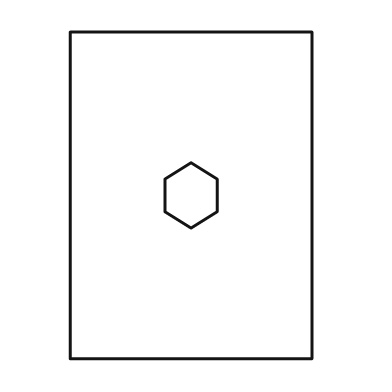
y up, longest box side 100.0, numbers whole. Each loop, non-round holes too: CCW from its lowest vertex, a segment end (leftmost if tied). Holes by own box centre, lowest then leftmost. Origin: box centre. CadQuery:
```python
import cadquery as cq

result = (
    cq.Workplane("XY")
    .moveTo(-37.0, -50.0)
    .lineTo(37.0, -50.0)
    .lineTo(37.0, 50.0)
    .lineTo(-37.0, 50.0)
    .close()
    .moveTo(0.0, -10.0)
    .lineTo(8.0, -5.0)
    .lineTo(8.0, 5.0)
    .lineTo(0.0, 10.0)
    .lineTo(-8.0, 5.0)
    .lineTo(-8.0, -5.0)
    .close()
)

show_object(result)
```